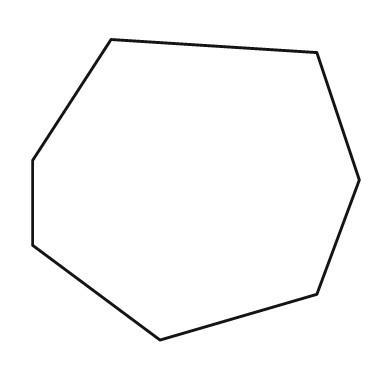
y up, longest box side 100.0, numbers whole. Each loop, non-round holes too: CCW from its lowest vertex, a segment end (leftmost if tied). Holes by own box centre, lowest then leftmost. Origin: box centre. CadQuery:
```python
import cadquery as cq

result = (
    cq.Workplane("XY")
    .moveTo(-11.0, -46.0)
    .lineTo(37.0, -32.0)
    .lineTo(50.0, 3.0)
    .lineTo(37.0, 42.0)
    .lineTo(-26.0, 46.0)
    .lineTo(-50.0, 9.0)
    .lineTo(-50.0, -17.0)
    .close()
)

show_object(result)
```